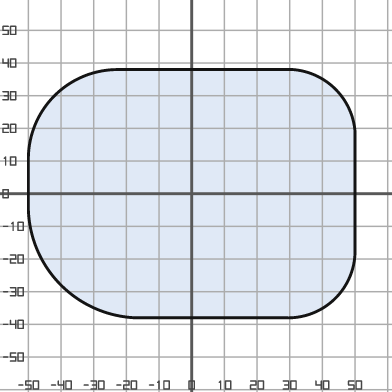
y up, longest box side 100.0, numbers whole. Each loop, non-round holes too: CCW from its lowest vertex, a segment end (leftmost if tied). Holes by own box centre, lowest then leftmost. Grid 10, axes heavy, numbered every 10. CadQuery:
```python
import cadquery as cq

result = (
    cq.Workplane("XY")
    .moveTo(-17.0, -38.0)
    .lineTo(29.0, -38.0)
    .threePointArc((44.0, -32.0), (50.0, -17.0))
    .lineTo(50.0, 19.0)
    .threePointArc((44.0, 32.0), (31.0, 38.0))
    .lineTo(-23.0, 38.0)
    .threePointArc((-42.0, 30.0), (-50.0, 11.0))
    .lineTo(-50.0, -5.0)
    .threePointArc((-40.0, -28.0), (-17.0, -38.0))
    .close()
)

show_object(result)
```